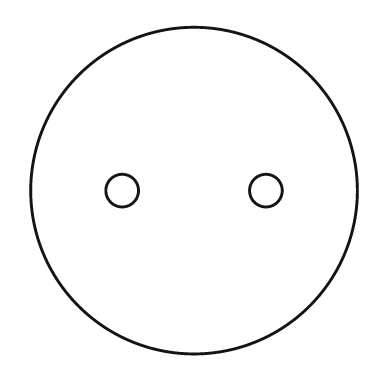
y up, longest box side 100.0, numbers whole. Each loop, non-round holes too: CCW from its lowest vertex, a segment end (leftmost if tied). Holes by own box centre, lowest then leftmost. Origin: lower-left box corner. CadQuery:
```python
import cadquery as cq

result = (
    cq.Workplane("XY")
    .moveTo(50.0, 50.0)
    .circle(50.0)
    .moveTo(28.0, 50.0)
    .circle(5.0)
    .moveTo(72.0, 50.0)
    .circle(5.0)
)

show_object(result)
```